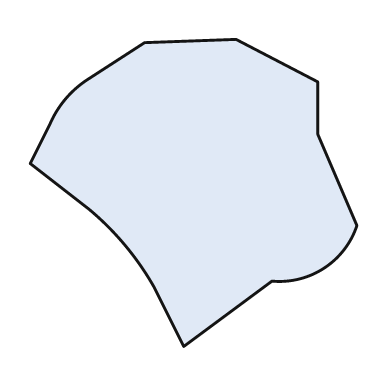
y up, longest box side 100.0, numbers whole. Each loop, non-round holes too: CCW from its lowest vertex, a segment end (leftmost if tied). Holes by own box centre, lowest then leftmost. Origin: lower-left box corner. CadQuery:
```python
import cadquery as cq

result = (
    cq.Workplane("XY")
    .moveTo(47.0, 0.0)
    .lineTo(74.0, 20.0)
    .threePointArc((90.0, 24.0), (100.0, 37.0))
    .lineTo(88.0, 65.0)
    .lineTo(88.0, 81.0)
    .lineTo(63.0, 94.0)
    .lineTo(35.0, 93.0)
    .lineTo(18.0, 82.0)
    .threePointArc((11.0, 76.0), (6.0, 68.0))
    .lineTo(0.0, 56.0)
    .lineTo(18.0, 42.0)
    .threePointArc((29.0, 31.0), (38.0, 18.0))
    .close()
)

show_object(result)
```